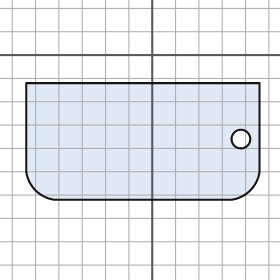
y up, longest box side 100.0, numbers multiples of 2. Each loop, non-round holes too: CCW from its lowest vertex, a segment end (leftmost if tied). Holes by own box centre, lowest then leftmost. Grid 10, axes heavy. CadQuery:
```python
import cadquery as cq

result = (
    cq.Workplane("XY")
    .moveTo(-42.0, -62.0)
    .lineTo(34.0, -62.0)
    .threePointArc((42.0, -58.0), (46.0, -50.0))
    .lineTo(46.0, -12.0)
    .lineTo(-54.0, -12.0)
    .lineTo(-54.0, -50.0)
    .threePointArc((-50.0, -58.0), (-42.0, -62.0))
    .close()
    .moveTo(38.0, -36.0)
    .circle(4.0)
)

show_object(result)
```